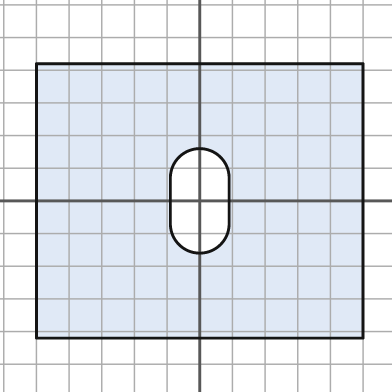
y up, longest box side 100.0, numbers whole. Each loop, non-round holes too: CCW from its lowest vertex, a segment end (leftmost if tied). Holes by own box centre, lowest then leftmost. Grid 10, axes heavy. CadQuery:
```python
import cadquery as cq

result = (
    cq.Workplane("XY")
    .moveTo(-50.0, -42.0)
    .lineTo(50.0, -42.0)
    .lineTo(50.0, 42.0)
    .lineTo(-50.0, 42.0)
    .close()
    .moveTo(-9.0, -7.0)
    .threePointArc((0.0, -16.0), (9.0, -7.0))
    .lineTo(9.0, 7.0)
    .threePointArc((0.0, 16.0), (-9.0, 7.0))
    .close()
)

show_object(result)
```